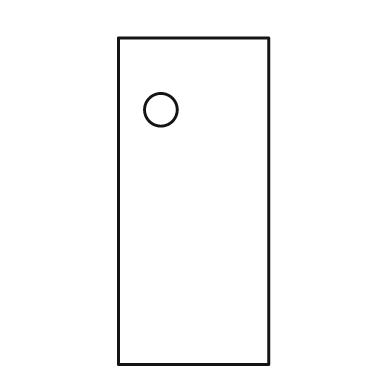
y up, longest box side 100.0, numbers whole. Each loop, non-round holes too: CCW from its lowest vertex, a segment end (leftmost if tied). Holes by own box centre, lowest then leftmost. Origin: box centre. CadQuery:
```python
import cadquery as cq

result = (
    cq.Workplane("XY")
    .moveTo(-23.0, -50.0)
    .lineTo(23.0, -50.0)
    .lineTo(23.0, 50.0)
    .lineTo(-23.0, 50.0)
    .close()
    .moveTo(-10.0, 28.0)
    .circle(5.0)
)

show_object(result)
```